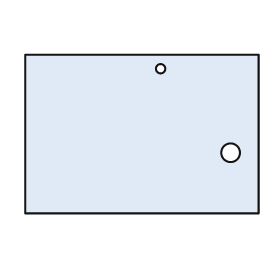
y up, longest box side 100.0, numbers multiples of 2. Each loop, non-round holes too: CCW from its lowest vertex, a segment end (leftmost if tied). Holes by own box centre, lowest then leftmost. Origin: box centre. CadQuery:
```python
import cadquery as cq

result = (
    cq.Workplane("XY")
    .moveTo(-50.0, -34.0)
    .lineTo(50.0, -34.0)
    .lineTo(50.0, 34.0)
    .lineTo(-50.0, 34.0)
    .close()
    .moveTo(38.0, -8.0)
    .circle(4.0)
    .moveTo(8.0, 28.0)
    .circle(2.0)
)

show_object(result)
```